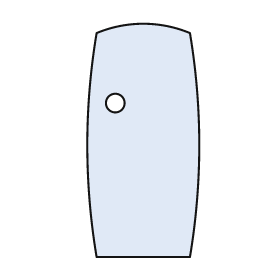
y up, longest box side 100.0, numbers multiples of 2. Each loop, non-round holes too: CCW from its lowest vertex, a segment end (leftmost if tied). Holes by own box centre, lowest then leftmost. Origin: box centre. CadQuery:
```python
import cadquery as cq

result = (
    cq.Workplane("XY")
    .moveTo(-20.0, -50.0)
    .lineTo(20.0, -50.0)
    .threePointArc((24.0, -2.0), (20.0, 46.0))
    .threePointArc((0.0, 50.0), (-20.0, 46.0))
    .threePointArc((-24.0, -2.0), (-20.0, -50.0))
    .close()
    .moveTo(-12.0, 16.0)
    .circle(4.0)
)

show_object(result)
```